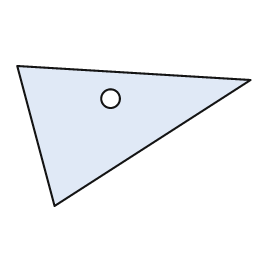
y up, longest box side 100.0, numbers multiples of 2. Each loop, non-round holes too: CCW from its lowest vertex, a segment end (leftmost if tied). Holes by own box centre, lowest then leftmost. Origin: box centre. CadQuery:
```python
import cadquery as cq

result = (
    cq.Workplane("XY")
    .moveTo(-34.0, -30.0)
    .lineTo(50.0, 24.0)
    .lineTo(-50.0, 30.0)
    .close()
    .moveTo(-10.0, 16.0)
    .circle(4.0)
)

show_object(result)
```